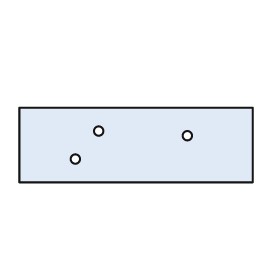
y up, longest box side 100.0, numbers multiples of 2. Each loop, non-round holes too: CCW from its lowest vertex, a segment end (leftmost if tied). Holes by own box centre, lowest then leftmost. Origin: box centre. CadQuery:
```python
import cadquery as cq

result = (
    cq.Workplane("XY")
    .moveTo(-50.0, -16.0)
    .lineTo(50.0, -16.0)
    .lineTo(50.0, 16.0)
    .lineTo(-50.0, 16.0)
    .close()
    .moveTo(-26.0, -6.0)
    .circle(2.0)
    .moveTo(22.0, 4.0)
    .circle(2.0)
    .moveTo(-16.0, 6.0)
    .circle(2.0)
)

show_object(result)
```